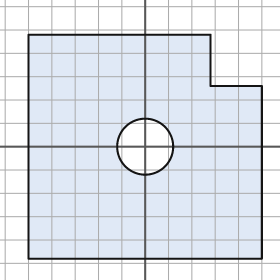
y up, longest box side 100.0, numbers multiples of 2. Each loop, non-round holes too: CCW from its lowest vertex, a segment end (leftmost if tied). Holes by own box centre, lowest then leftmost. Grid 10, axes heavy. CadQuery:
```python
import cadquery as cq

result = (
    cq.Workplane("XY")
    .moveTo(-50.0, -48.0)
    .lineTo(50.0, -48.0)
    .lineTo(50.0, 26.0)
    .lineTo(28.0, 26.0)
    .lineTo(28.0, 48.0)
    .lineTo(-50.0, 48.0)
    .close()
    .moveTo(0.0, 0.0)
    .circle(12.0)
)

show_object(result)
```